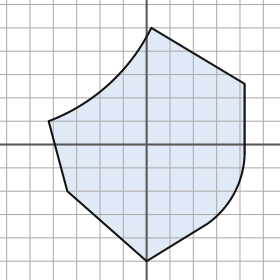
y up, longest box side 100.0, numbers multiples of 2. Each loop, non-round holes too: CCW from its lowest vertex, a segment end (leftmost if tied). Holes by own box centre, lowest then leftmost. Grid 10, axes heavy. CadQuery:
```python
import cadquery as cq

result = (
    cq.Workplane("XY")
    .moveTo(0.0, -50.0)
    .lineTo(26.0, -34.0)
    .threePointArc((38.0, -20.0), (42.0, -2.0))
    .lineTo(42.0, 26.0)
    .lineTo(2.0, 50.0)
    .threePointArc((-16.0, 26.0), (-42.0, 10.0))
    .lineTo(-34.0, -20.0)
    .close()
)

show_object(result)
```